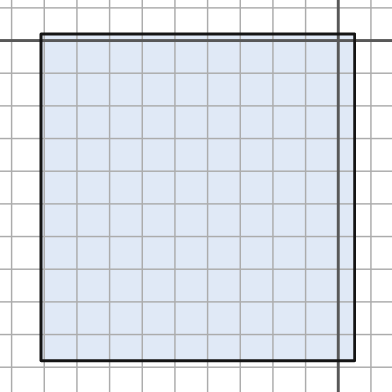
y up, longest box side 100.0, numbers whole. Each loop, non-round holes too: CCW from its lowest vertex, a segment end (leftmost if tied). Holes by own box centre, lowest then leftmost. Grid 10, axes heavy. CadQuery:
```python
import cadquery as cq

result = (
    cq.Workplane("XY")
    .moveTo(-91.0, -98.0)
    .lineTo(5.0, -98.0)
    .lineTo(5.0, 2.0)
    .lineTo(-91.0, 2.0)
    .close()
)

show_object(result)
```